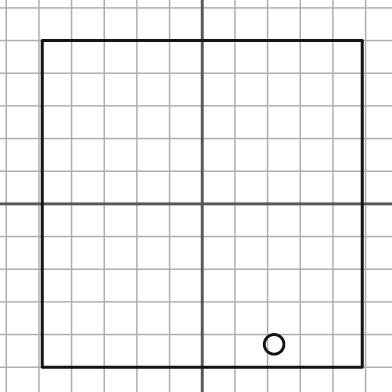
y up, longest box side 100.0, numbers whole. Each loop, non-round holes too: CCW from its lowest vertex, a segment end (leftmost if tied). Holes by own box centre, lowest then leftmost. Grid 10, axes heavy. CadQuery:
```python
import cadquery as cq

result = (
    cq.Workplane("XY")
    .moveTo(-49.0, -50.0)
    .lineTo(49.0, -50.0)
    .lineTo(49.0, 50.0)
    .lineTo(-49.0, 50.0)
    .close()
    .moveTo(22.0, -43.0)
    .circle(3.0)
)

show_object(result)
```